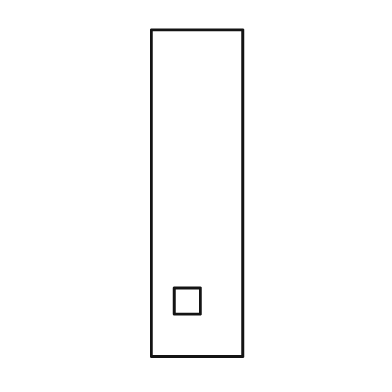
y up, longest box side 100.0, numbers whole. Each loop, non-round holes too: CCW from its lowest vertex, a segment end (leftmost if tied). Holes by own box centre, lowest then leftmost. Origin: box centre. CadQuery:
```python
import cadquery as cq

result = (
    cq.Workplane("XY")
    .moveTo(-14.0, -50.0)
    .lineTo(14.0, -50.0)
    .lineTo(14.0, 50.0)
    .lineTo(-14.0, 50.0)
    .close()
    .moveTo(-7.0, -37.0)
    .lineTo(1.0, -37.0)
    .lineTo(1.0, -29.0)
    .lineTo(-7.0, -29.0)
    .close()
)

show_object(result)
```